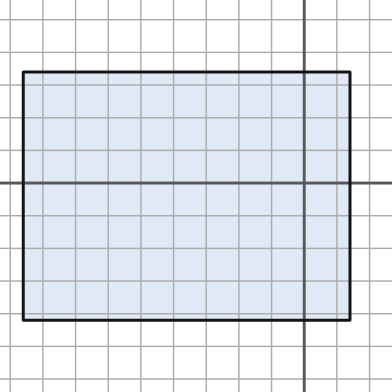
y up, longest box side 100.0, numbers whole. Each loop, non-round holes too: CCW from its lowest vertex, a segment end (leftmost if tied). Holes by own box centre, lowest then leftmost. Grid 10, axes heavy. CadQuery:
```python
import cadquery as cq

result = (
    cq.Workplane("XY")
    .moveTo(-86.0, -42.0)
    .lineTo(14.0, -42.0)
    .lineTo(14.0, 34.0)
    .lineTo(-86.0, 34.0)
    .close()
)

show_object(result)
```